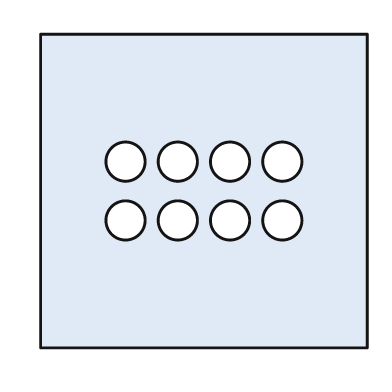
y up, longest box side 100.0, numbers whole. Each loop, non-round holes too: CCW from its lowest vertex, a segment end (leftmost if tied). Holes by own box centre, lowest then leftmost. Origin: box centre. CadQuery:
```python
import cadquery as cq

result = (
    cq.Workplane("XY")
    .moveTo(-50.0, -48.0)
    .lineTo(50.0, -48.0)
    .lineTo(50.0, 48.0)
    .lineTo(-50.0, 48.0)
    .close()
    .moveTo(-24.0, -9.0)
    .circle(6.0)
    .moveTo(-8.0, -9.0)
    .circle(6.0)
    .moveTo(8.0, -9.0)
    .circle(6.0)
    .moveTo(24.0, -9.0)
    .circle(6.0)
    .moveTo(-24.0, 9.0)
    .circle(6.0)
    .moveTo(-8.0, 9.0)
    .circle(6.0)
    .moveTo(8.0, 9.0)
    .circle(6.0)
    .moveTo(24.0, 9.0)
    .circle(6.0)
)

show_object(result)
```